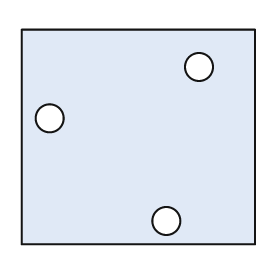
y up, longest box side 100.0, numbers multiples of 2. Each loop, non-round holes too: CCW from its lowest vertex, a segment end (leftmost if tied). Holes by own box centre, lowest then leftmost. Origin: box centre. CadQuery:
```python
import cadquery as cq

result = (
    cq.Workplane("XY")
    .moveTo(-50.0, -46.0)
    .lineTo(50.0, -46.0)
    .lineTo(50.0, 46.0)
    .lineTo(-50.0, 46.0)
    .close()
    .moveTo(12.0, -36.0)
    .circle(6.0)
    .moveTo(-38.0, 8.0)
    .circle(6.0)
    .moveTo(26.0, 30.0)
    .circle(6.0)
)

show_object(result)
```